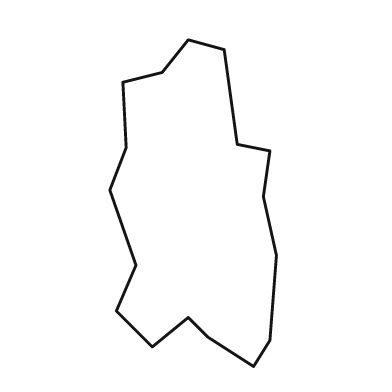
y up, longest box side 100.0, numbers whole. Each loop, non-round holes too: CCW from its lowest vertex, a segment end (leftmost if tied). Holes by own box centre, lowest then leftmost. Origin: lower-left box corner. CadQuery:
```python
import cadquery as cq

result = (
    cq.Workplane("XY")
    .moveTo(44.0, 0.0)
    .lineTo(49.0, 8.0)
    .lineTo(51.0, 34.0)
    .lineTo(47.0, 52.0)
    .lineTo(49.0, 66.0)
    .lineTo(39.0, 68.0)
    .lineTo(35.0, 97.0)
    .lineTo(24.0, 100.0)
    .lineTo(16.0, 90.0)
    .lineTo(4.0, 87.0)
    .lineTo(5.0, 67.0)
    .lineTo(0.0, 54.0)
    .lineTo(8.0, 31.0)
    .lineTo(2.0, 17.0)
    .lineTo(13.0, 6.0)
    .lineTo(24.0, 15.0)
    .lineTo(30.0, 9.0)
    .close()
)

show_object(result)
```